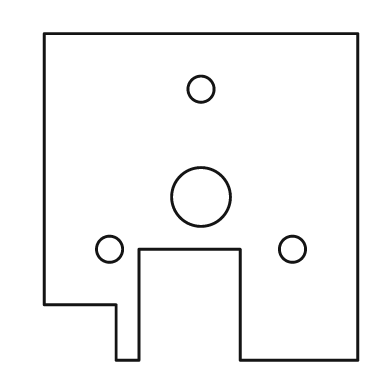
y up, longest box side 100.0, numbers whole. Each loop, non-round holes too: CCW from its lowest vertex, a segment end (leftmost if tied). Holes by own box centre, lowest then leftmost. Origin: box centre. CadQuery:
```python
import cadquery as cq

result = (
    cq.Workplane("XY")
    .moveTo(-26.0, -50.0)
    .lineTo(-19.0, -50.0)
    .lineTo(-19.0, -16.0)
    .lineTo(12.0, -16.0)
    .lineTo(12.0, -50.0)
    .lineTo(48.0, -50.0)
    .lineTo(48.0, 50.0)
    .lineTo(-48.0, 50.0)
    .lineTo(-48.0, -33.0)
    .lineTo(-26.0, -33.0)
    .close()
    .moveTo(-28.0, -16.0)
    .circle(4.0)
    .moveTo(28.0, -16.0)
    .circle(4.0)
    .moveTo(0.0, 0.0)
    .circle(9.0)
    .moveTo(0.0, 33.0)
    .circle(4.0)
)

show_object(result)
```